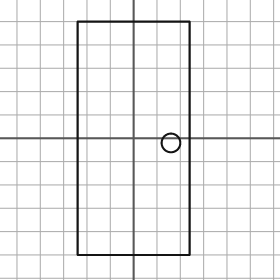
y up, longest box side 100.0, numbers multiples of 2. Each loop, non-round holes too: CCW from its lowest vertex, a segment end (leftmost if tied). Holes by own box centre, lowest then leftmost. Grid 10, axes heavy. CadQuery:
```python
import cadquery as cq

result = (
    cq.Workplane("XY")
    .moveTo(-24.0, -50.0)
    .lineTo(24.0, -50.0)
    .lineTo(24.0, 50.0)
    .lineTo(-24.0, 50.0)
    .close()
    .moveTo(16.0, -2.0)
    .circle(4.0)
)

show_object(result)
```